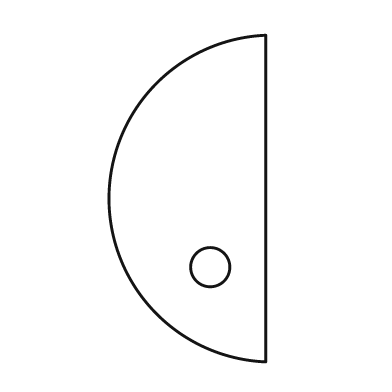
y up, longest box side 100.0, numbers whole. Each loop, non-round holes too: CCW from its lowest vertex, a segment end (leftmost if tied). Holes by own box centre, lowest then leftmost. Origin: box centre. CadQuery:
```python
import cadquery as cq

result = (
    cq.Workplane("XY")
    .moveTo(24.0, -50.0)
    .lineTo(24.0, 50.0)
    .threePointArc((-24.0, 0.0), (24.0, -50.0))
    .close()
    .moveTo(7.0, -21.0)
    .circle(6.0)
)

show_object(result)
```